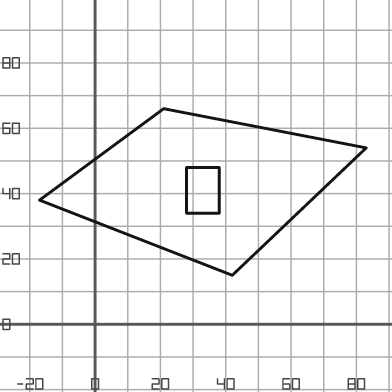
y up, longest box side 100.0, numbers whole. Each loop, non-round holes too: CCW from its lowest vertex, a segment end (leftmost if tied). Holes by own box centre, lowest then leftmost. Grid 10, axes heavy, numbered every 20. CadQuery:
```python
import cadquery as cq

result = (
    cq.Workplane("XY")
    .moveTo(42.0, 15.0)
    .lineTo(83.0, 54.0)
    .lineTo(21.0, 66.0)
    .lineTo(-17.0, 38.0)
    .close()
    .moveTo(28.0, 34.0)
    .lineTo(38.0, 34.0)
    .lineTo(38.0, 48.0)
    .lineTo(28.0, 48.0)
    .close()
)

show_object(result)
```